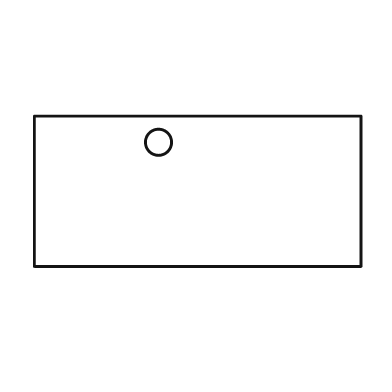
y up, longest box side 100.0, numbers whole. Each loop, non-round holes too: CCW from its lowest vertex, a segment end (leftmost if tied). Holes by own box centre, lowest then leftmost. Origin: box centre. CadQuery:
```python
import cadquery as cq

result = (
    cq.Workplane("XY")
    .moveTo(-50.0, -23.0)
    .lineTo(50.0, -23.0)
    .lineTo(50.0, 23.0)
    .lineTo(-50.0, 23.0)
    .close()
    .moveTo(-12.0, 15.0)
    .circle(4.0)
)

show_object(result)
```